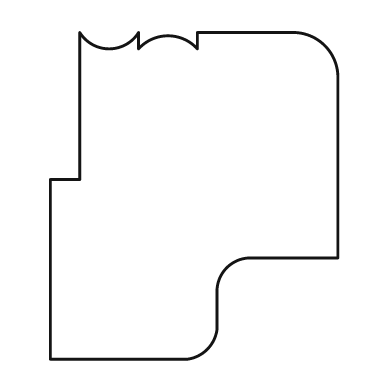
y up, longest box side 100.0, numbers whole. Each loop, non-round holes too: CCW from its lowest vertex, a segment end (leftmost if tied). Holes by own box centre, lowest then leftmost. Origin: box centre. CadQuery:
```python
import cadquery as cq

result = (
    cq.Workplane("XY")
    .moveTo(-44.0, -50.0)
    .lineTo(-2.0, -50.0)
    .threePointArc((4.0, -47.0), (7.0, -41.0))
    .lineTo(7.0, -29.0)
    .threePointArc((10.0, -22.0), (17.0, -19.0))
    .lineTo(44.0, -19.0)
    .lineTo(44.0, 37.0)
    .threePointArc((40.0, 46.0), (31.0, 50.0))
    .lineTo(1.0, 50.0)
    .lineTo(1.0, 45.0)
    .threePointArc((-8.0, 49.0), (-17.0, 45.0))
    .lineTo(-17.0, 50.0)
    .threePointArc((-26.0, 45.0), (-35.0, 50.0))
    .lineTo(-35.0, 5.0)
    .lineTo(-44.0, 5.0)
    .close()
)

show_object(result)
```